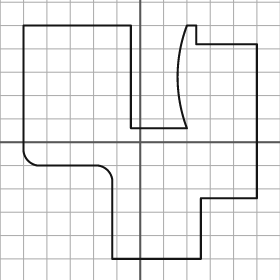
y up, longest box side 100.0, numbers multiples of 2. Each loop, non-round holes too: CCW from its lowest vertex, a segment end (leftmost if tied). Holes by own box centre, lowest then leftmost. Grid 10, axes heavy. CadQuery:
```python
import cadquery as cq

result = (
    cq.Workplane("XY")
    .moveTo(-12.0, -50.0)
    .lineTo(26.0, -50.0)
    .lineTo(26.0, -24.0)
    .lineTo(50.0, -24.0)
    .lineTo(50.0, 42.0)
    .lineTo(24.0, 42.0)
    .lineTo(24.0, 50.0)
    .lineTo(20.0, 50.0)
    .threePointArc((16.0, 28.0), (20.0, 6.0))
    .lineTo(-4.0, 6.0)
    .lineTo(-4.0, 50.0)
    .lineTo(-50.0, 50.0)
    .lineTo(-50.0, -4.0)
    .threePointArc((-48.0, -8.0), (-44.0, -10.0))
    .lineTo(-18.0, -10.0)
    .threePointArc((-14.0, -12.0), (-12.0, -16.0))
    .close()
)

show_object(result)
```